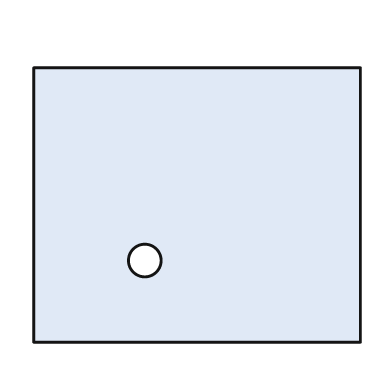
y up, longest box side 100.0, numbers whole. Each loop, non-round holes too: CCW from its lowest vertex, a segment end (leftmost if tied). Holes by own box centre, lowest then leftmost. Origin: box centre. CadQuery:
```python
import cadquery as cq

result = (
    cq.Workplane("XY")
    .moveTo(-50.0, -42.0)
    .lineTo(50.0, -42.0)
    .lineTo(50.0, 42.0)
    .lineTo(-50.0, 42.0)
    .close()
    .moveTo(-16.0, -17.0)
    .circle(5.0)
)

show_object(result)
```